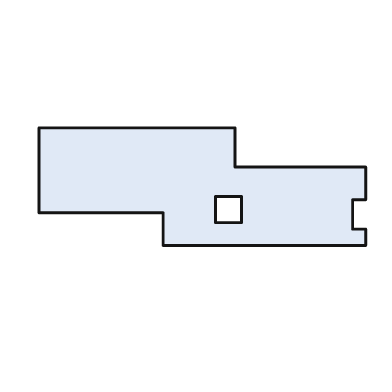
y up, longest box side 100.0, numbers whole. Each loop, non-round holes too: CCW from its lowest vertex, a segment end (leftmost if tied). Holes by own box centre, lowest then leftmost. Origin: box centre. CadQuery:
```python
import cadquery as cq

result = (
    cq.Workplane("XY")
    .moveTo(-12.0, -18.0)
    .lineTo(50.0, -18.0)
    .lineTo(50.0, -13.0)
    .lineTo(46.0, -13.0)
    .lineTo(46.0, -4.0)
    .lineTo(50.0, -4.0)
    .lineTo(50.0, 6.0)
    .lineTo(10.0, 6.0)
    .lineTo(10.0, 18.0)
    .lineTo(-50.0, 18.0)
    .lineTo(-50.0, -8.0)
    .lineTo(-12.0, -8.0)
    .close()
    .moveTo(4.0, -11.0)
    .lineTo(12.0, -11.0)
    .lineTo(12.0, -3.0)
    .lineTo(4.0, -3.0)
    .close()
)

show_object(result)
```